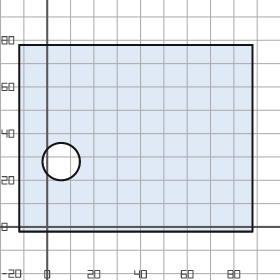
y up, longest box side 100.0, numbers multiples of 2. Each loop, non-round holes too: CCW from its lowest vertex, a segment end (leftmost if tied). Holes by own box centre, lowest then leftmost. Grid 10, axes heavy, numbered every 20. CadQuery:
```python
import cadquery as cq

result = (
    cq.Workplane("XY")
    .moveTo(-12.0, -2.0)
    .lineTo(88.0, -2.0)
    .lineTo(88.0, 78.0)
    .lineTo(-12.0, 78.0)
    .close()
    .moveTo(6.0, 28.0)
    .circle(8.0)
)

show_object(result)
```